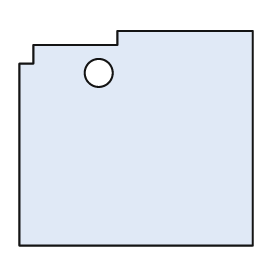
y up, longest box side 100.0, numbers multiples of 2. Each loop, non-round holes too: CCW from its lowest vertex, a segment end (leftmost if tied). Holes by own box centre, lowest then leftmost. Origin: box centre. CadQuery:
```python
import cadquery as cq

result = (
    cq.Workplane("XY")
    .moveTo(-50.0, -46.0)
    .lineTo(50.0, -46.0)
    .lineTo(50.0, 46.0)
    .lineTo(-8.0, 46.0)
    .lineTo(-8.0, 40.0)
    .lineTo(-44.0, 40.0)
    .lineTo(-44.0, 32.0)
    .lineTo(-50.0, 32.0)
    .close()
    .moveTo(-16.0, 28.0)
    .circle(6.0)
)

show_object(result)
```